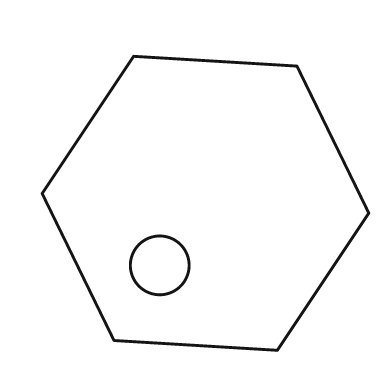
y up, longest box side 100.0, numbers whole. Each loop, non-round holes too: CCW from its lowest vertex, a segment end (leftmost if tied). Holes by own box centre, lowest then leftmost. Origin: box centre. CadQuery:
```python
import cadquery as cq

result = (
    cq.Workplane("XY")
    .moveTo(22.0, -45.0)
    .lineTo(50.0, -3.0)
    .lineTo(28.0, 42.0)
    .lineTo(-22.0, 45.0)
    .lineTo(-50.0, 3.0)
    .lineTo(-28.0, -42.0)
    .close()
    .moveTo(-14.0, -19.0)
    .circle(9.0)
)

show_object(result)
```